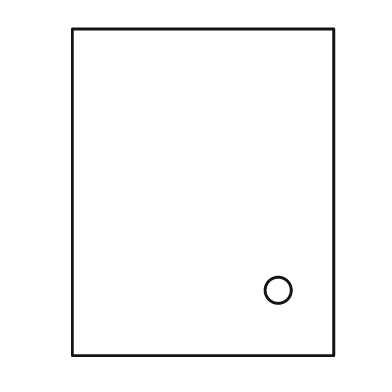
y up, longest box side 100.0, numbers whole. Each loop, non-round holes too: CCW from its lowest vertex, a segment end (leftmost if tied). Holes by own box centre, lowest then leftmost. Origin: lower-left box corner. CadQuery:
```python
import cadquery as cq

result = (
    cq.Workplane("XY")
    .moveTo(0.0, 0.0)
    .lineTo(80.0, 0.0)
    .lineTo(80.0, 100.0)
    .lineTo(0.0, 100.0)
    .close()
    .moveTo(63.0, 20.0)
    .circle(4.0)
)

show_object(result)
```